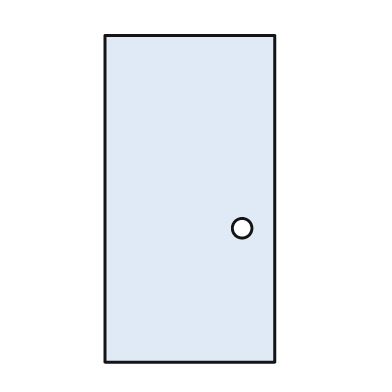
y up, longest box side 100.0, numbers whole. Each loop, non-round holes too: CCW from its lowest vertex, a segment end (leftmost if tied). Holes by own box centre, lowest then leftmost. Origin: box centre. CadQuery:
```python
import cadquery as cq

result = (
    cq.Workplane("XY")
    .moveTo(-26.0, -50.0)
    .lineTo(26.0, -50.0)
    .lineTo(26.0, 50.0)
    .lineTo(-26.0, 50.0)
    .close()
    .moveTo(16.0, -9.0)
    .circle(3.0)
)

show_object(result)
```